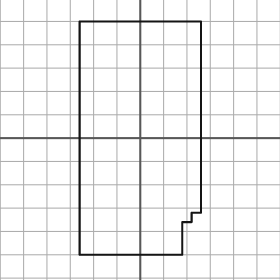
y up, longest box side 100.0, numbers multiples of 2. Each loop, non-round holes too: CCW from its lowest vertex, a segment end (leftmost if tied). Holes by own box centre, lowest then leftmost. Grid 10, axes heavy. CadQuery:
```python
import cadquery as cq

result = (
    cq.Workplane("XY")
    .moveTo(-26.0, -50.0)
    .lineTo(18.0, -50.0)
    .lineTo(18.0, -36.0)
    .lineTo(22.0, -36.0)
    .lineTo(22.0, -32.0)
    .lineTo(26.0, -32.0)
    .lineTo(26.0, 50.0)
    .lineTo(-26.0, 50.0)
    .close()
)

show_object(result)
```